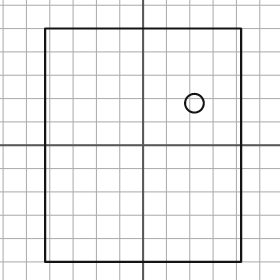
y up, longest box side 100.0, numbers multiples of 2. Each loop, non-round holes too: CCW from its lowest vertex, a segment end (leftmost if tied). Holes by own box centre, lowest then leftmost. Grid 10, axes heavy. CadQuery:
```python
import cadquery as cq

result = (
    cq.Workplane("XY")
    .moveTo(-42.0, -50.0)
    .lineTo(42.0, -50.0)
    .lineTo(42.0, 50.0)
    .lineTo(-42.0, 50.0)
    .close()
    .moveTo(22.0, 18.0)
    .circle(4.0)
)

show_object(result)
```